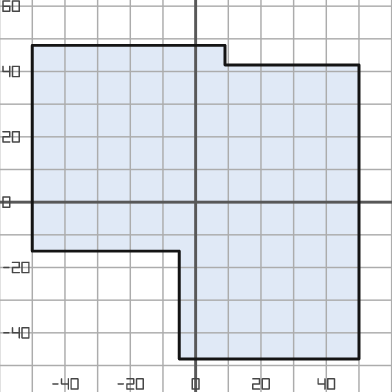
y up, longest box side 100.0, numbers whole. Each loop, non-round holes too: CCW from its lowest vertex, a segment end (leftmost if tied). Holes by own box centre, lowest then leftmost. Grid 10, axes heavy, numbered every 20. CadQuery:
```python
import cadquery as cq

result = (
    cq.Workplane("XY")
    .moveTo(-5.0, -48.0)
    .lineTo(50.0, -48.0)
    .lineTo(50.0, 42.0)
    .lineTo(9.0, 42.0)
    .lineTo(9.0, 48.0)
    .lineTo(-50.0, 48.0)
    .lineTo(-50.0, -15.0)
    .lineTo(-5.0, -15.0)
    .close()
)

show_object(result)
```